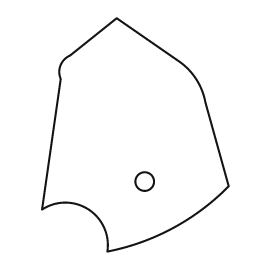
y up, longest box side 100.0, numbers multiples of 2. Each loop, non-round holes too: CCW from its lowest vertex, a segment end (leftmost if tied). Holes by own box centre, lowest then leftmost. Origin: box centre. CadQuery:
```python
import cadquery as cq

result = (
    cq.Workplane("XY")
    .moveTo(-12.0, -50.0)
    .threePointArc((16.0, -40.0), (40.0, -22.0))
    .lineTo(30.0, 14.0)
    .threePointArc((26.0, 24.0), (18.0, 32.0))
    .lineTo(-8.0, 50.0)
    .lineTo(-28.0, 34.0)
    .threePointArc((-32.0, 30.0), (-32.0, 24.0))
    .lineTo(-40.0, -32.0)
    .threePointArc((-20.0, -32.0), (-12.0, -50.0))
    .close()
    .moveTo(4.0, -20.0)
    .circle(4.0)
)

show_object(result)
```